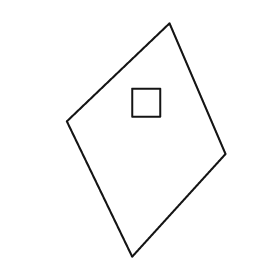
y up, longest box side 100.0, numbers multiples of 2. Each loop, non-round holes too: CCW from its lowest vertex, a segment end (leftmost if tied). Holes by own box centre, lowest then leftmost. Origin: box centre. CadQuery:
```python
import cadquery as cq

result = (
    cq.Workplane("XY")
    .moveTo(-6.0, -50.0)
    .lineTo(34.0, -6.0)
    .lineTo(10.0, 50.0)
    .lineTo(-34.0, 8.0)
    .close()
    .moveTo(-6.0, 10.0)
    .lineTo(6.0, 10.0)
    .lineTo(6.0, 22.0)
    .lineTo(-6.0, 22.0)
    .close()
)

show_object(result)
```